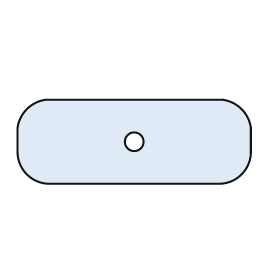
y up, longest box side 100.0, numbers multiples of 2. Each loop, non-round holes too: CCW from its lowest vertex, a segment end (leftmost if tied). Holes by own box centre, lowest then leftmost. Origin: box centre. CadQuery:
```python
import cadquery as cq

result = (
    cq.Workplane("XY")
    .moveTo(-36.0, -18.0)
    .lineTo(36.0, -18.0)
    .threePointArc((46.0, -14.0), (50.0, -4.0))
    .lineTo(50.0, 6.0)
    .threePointArc((46.0, 14.0), (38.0, 18.0))
    .lineTo(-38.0, 18.0)
    .threePointArc((-46.0, 14.0), (-50.0, 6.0))
    .lineTo(-50.0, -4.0)
    .threePointArc((-46.0, -14.0), (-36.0, -18.0))
    .close()
    .moveTo(0.0, 0.0)
    .circle(4.0)
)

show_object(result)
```